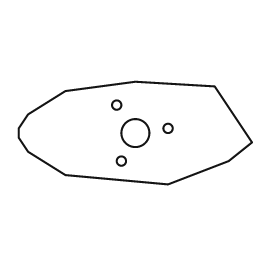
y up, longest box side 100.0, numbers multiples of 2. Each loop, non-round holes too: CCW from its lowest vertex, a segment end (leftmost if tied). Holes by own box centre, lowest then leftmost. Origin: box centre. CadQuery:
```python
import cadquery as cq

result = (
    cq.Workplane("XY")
    .moveTo(14.0, -22.0)
    .lineTo(40.0, -12.0)
    .lineTo(50.0, -4.0)
    .lineTo(34.0, 20.0)
    .lineTo(0.0, 22.0)
    .lineTo(-30.0, 18.0)
    .lineTo(-46.0, 8.0)
    .lineTo(-50.0, 2.0)
    .lineTo(-50.0, -2.0)
    .lineTo(-46.0, -8.0)
    .lineTo(-30.0, -18.0)
    .close()
    .moveTo(-6.0, -12.0)
    .circle(2.0)
    .moveTo(0.0, 0.0)
    .circle(6.0)
    .moveTo(14.0, 2.0)
    .circle(2.0)
    .moveTo(-8.0, 12.0)
    .circle(2.0)
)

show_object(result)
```